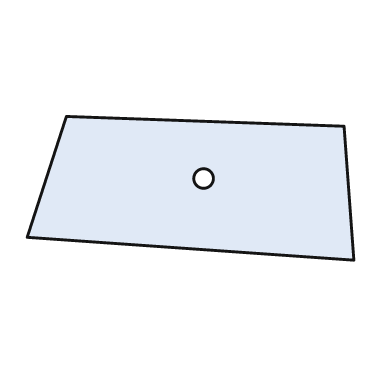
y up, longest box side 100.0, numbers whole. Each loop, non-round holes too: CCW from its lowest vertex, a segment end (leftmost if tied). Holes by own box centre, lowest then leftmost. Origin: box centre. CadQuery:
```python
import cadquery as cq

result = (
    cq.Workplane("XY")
    .moveTo(50.0, -22.0)
    .lineTo(47.0, 19.0)
    .lineTo(-38.0, 22.0)
    .lineTo(-50.0, -15.0)
    .close()
    .moveTo(4.0, 3.0)
    .circle(3.0)
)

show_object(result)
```